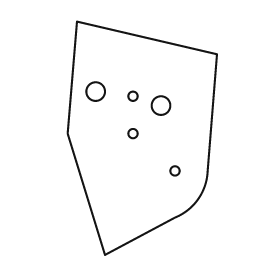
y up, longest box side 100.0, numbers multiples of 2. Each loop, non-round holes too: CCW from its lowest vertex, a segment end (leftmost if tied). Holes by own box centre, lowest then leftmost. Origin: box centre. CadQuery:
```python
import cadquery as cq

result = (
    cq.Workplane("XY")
    .moveTo(-16.0, -50.0)
    .lineTo(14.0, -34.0)
    .threePointArc((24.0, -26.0), (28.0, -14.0))
    .lineTo(32.0, 36.0)
    .lineTo(-28.0, 50.0)
    .lineTo(-32.0, 2.0)
    .close()
    .moveTo(14.0, -14.0)
    .circle(2.0)
    .moveTo(-4.0, 2.0)
    .circle(2.0)
    .moveTo(8.0, 14.0)
    .circle(4.0)
    .moveTo(-4.0, 18.0)
    .circle(2.0)
    .moveTo(-20.0, 20.0)
    .circle(4.0)
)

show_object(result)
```